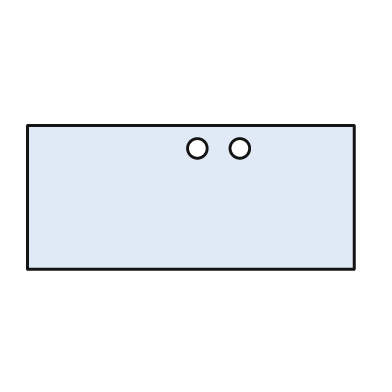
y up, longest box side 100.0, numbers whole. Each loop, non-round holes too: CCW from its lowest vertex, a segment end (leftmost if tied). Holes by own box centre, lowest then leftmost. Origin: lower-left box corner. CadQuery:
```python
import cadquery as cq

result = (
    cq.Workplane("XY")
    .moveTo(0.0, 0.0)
    .lineTo(100.0, 0.0)
    .lineTo(100.0, 44.0)
    .lineTo(0.0, 44.0)
    .close()
    .moveTo(52.0, 37.0)
    .circle(3.0)
    .moveTo(65.0, 37.0)
    .circle(3.0)
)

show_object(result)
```